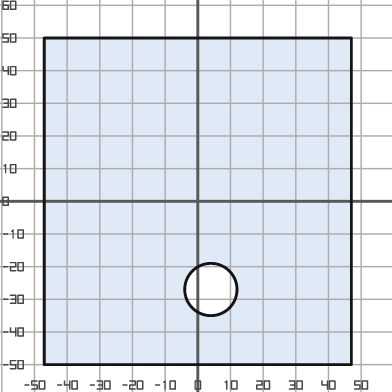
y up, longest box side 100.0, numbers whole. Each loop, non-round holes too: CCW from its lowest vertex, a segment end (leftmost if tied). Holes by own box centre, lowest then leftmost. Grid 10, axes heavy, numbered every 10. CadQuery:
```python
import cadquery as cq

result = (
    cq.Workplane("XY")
    .moveTo(-47.0, -50.0)
    .lineTo(47.0, -50.0)
    .lineTo(47.0, 50.0)
    .lineTo(-47.0, 50.0)
    .close()
    .moveTo(4.0, -27.0)
    .circle(8.0)
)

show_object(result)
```